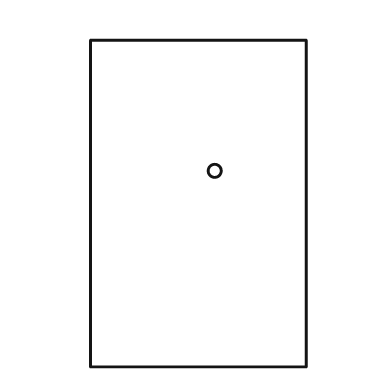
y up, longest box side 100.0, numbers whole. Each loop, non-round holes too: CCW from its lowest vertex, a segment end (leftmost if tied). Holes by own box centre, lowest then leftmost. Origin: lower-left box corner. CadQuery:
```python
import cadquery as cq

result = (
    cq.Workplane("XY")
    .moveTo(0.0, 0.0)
    .lineTo(66.0, 0.0)
    .lineTo(66.0, 100.0)
    .lineTo(0.0, 100.0)
    .close()
    .moveTo(38.0, 60.0)
    .circle(2.0)
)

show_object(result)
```